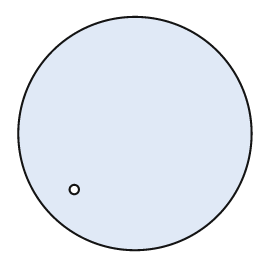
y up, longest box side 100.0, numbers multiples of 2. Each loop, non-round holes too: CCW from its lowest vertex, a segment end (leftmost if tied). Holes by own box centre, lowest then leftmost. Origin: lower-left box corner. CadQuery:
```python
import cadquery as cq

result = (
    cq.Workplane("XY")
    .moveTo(50.0, 50.0)
    .circle(50.0)
    .moveTo(24.0, 26.0)
    .circle(2.0)
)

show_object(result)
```